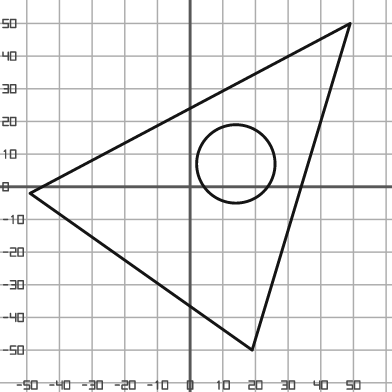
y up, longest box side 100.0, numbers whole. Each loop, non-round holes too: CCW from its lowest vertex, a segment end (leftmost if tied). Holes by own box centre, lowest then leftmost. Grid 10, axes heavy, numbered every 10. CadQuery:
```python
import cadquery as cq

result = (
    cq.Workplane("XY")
    .moveTo(19.0, -50.0)
    .lineTo(49.0, 50.0)
    .lineTo(-49.0, -2.0)
    .close()
    .moveTo(14.0, 7.0)
    .circle(12.0)
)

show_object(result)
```